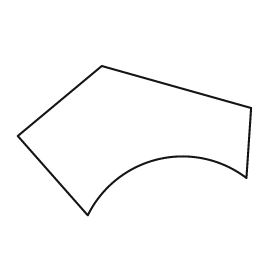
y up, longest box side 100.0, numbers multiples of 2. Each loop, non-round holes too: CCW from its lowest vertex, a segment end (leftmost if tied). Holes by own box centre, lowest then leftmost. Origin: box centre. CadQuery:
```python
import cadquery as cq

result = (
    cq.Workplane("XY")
    .moveTo(-20.0, -32.0)
    .threePointArc((10.0, -8.0), (48.0, -16.0))
    .lineTo(50.0, 14.0)
    .lineTo(-14.0, 32.0)
    .lineTo(-50.0, 2.0)
    .close()
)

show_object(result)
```